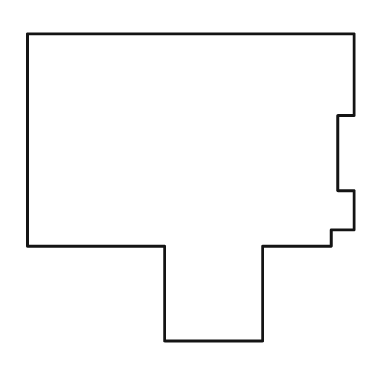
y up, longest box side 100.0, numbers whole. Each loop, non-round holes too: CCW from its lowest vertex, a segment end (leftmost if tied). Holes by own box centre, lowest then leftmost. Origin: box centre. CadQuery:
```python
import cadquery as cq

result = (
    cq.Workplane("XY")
    .moveTo(-8.0, -47.0)
    .lineTo(22.0, -47.0)
    .lineTo(22.0, -18.0)
    .lineTo(43.0, -18.0)
    .lineTo(43.0, -13.0)
    .lineTo(50.0, -13.0)
    .lineTo(50.0, -1.0)
    .lineTo(45.0, -1.0)
    .lineTo(45.0, 22.0)
    .lineTo(50.0, 22.0)
    .lineTo(50.0, 47.0)
    .lineTo(-50.0, 47.0)
    .lineTo(-50.0, -18.0)
    .lineTo(-8.0, -18.0)
    .close()
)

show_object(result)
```